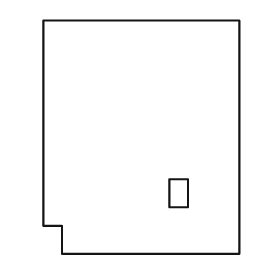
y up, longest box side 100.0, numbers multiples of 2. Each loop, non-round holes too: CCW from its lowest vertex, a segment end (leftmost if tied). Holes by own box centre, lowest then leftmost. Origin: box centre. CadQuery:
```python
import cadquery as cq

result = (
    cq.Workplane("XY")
    .moveTo(-34.0, -50.0)
    .lineTo(42.0, -50.0)
    .lineTo(42.0, 50.0)
    .lineTo(-42.0, 50.0)
    .lineTo(-42.0, -38.0)
    .lineTo(-34.0, -38.0)
    .close()
    .moveTo(12.0, -30.0)
    .lineTo(20.0, -30.0)
    .lineTo(20.0, -18.0)
    .lineTo(12.0, -18.0)
    .close()
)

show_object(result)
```